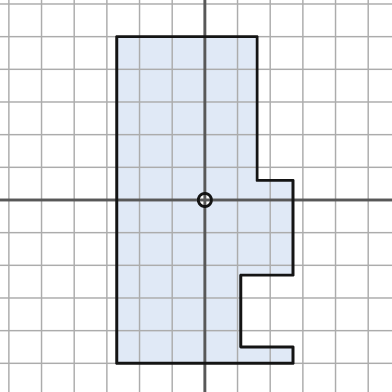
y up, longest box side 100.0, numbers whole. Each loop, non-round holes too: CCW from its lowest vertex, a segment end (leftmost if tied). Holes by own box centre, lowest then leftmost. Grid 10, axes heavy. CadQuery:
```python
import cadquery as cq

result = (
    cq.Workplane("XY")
    .moveTo(-27.0, -50.0)
    .lineTo(27.0, -50.0)
    .lineTo(27.0, -45.0)
    .lineTo(11.0, -45.0)
    .lineTo(11.0, -23.0)
    .lineTo(27.0, -23.0)
    .lineTo(27.0, 6.0)
    .lineTo(16.0, 6.0)
    .lineTo(16.0, 50.0)
    .lineTo(-27.0, 50.0)
    .close()
    .moveTo(0.0, 0.0)
    .circle(2.0)
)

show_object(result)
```